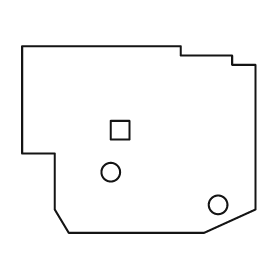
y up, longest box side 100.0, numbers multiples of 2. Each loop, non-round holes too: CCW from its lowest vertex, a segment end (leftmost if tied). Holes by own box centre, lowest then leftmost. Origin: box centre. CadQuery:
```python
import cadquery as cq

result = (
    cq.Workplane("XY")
    .moveTo(-30.0, -40.0)
    .lineTo(28.0, -40.0)
    .lineTo(50.0, -30.0)
    .lineTo(50.0, 32.0)
    .lineTo(40.0, 32.0)
    .lineTo(40.0, 36.0)
    .lineTo(18.0, 36.0)
    .lineTo(18.0, 40.0)
    .lineTo(-50.0, 40.0)
    .lineTo(-50.0, -6.0)
    .lineTo(-36.0, -6.0)
    .lineTo(-36.0, -30.0)
    .close()
    .moveTo(34.0, -28.0)
    .circle(4.0)
    .moveTo(-12.0, -14.0)
    .circle(4.0)
    .moveTo(-12.0, 0.0)
    .lineTo(-4.0, 0.0)
    .lineTo(-4.0, 8.0)
    .lineTo(-12.0, 8.0)
    .close()
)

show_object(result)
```